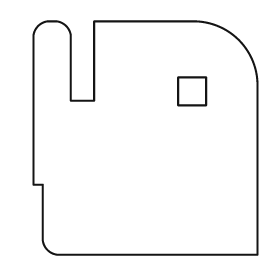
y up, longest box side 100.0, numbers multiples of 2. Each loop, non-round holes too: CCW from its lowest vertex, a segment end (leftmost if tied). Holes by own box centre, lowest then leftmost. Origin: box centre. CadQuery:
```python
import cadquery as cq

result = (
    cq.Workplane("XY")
    .moveTo(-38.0, -50.0)
    .lineTo(48.0, -50.0)
    .lineTo(48.0, 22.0)
    .threePointArc((40.0, 42.0), (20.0, 50.0))
    .lineTo(-22.0, 50.0)
    .lineTo(-22.0, 16.0)
    .lineTo(-32.0, 16.0)
    .lineTo(-32.0, 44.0)
    .threePointArc((-34.0, 48.0), (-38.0, 50.0))
    .lineTo(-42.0, 50.0)
    .threePointArc((-46.0, 48.0), (-48.0, 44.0))
    .lineTo(-48.0, -20.0)
    .lineTo(-44.0, -20.0)
    .lineTo(-44.0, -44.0)
    .threePointArc((-42.0, -48.0), (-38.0, -50.0))
    .close()
    .moveTo(14.0, 14.0)
    .lineTo(26.0, 14.0)
    .lineTo(26.0, 26.0)
    .lineTo(14.0, 26.0)
    .close()
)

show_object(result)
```